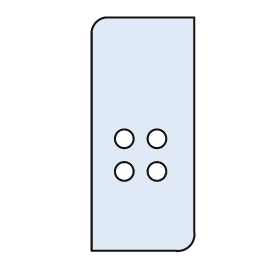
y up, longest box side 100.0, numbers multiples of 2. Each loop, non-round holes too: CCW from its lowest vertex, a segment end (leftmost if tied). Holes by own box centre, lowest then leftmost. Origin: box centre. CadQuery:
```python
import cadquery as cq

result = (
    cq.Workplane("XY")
    .moveTo(-22.0, -50.0)
    .lineTo(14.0, -50.0)
    .threePointArc((20.0, -48.0), (22.0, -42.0))
    .lineTo(22.0, 50.0)
    .lineTo(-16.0, 50.0)
    .threePointArc((-20.0, 48.0), (-22.0, 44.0))
    .close()
    .moveTo(-8.0, -16.0)
    .circle(4.0)
    .moveTo(6.0, -16.0)
    .circle(4.0)
    .moveTo(-8.0, -2.0)
    .circle(4.0)
    .moveTo(6.0, -2.0)
    .circle(4.0)
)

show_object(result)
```